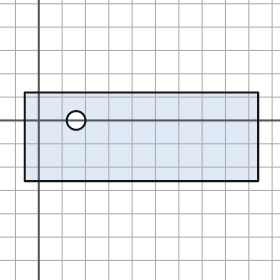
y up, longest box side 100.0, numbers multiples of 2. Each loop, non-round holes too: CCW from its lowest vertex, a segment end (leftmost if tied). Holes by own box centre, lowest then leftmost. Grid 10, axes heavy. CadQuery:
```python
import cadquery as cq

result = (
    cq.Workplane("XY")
    .moveTo(-6.0, -26.0)
    .lineTo(94.0, -26.0)
    .lineTo(94.0, 12.0)
    .lineTo(-6.0, 12.0)
    .close()
    .moveTo(16.0, 0.0)
    .circle(4.0)
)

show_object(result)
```